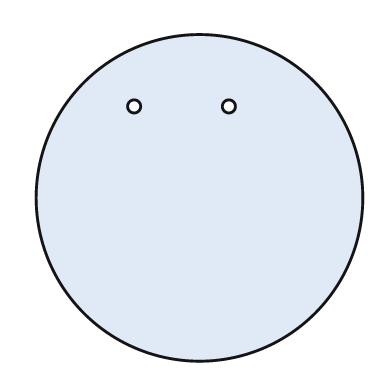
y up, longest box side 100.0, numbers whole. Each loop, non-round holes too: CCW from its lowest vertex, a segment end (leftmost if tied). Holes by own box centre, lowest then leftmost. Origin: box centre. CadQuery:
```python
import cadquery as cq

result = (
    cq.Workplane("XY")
    .moveTo(0.0, 0.0)
    .circle(50.0)
    .moveTo(-20.0, 28.0)
    .circle(2.0)
    .moveTo(9.0, 28.0)
    .circle(2.0)
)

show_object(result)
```